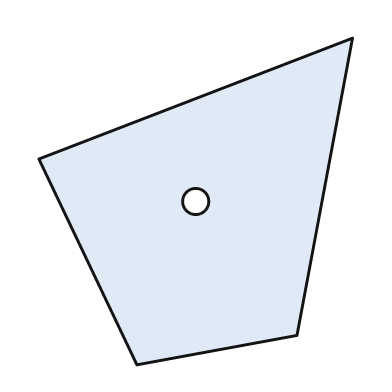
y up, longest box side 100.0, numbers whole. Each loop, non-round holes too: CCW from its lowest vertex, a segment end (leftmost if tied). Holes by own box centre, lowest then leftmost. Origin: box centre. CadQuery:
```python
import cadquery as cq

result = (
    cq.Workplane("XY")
    .moveTo(-18.0, -50.0)
    .lineTo(31.0, -41.0)
    .lineTo(48.0, 50.0)
    .lineTo(-48.0, 13.0)
    .close()
    .moveTo(0.0, 0.0)
    .circle(4.0)
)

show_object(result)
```